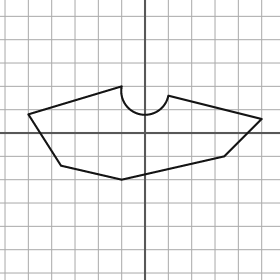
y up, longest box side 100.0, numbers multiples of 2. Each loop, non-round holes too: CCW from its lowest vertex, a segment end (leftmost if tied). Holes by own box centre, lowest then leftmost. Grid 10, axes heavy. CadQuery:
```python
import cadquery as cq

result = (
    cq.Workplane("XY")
    .moveTo(-10.0, -20.0)
    .lineTo(34.0, -10.0)
    .lineTo(50.0, 6.0)
    .lineTo(10.0, 16.0)
    .threePointArc((-2.0, 8.0), (-10.0, 20.0))
    .lineTo(-50.0, 8.0)
    .lineTo(-36.0, -14.0)
    .close()
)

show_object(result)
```